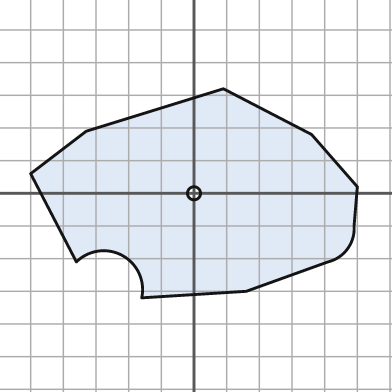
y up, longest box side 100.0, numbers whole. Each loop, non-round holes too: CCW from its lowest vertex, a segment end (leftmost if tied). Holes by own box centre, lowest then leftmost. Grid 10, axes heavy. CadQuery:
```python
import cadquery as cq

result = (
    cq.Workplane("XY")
    .moveTo(-16.0, -32.0)
    .lineTo(16.0, -30.0)
    .lineTo(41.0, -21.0)
    .threePointArc((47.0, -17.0), (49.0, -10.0))
    .lineTo(50.0, 2.0)
    .lineTo(36.0, 18.0)
    .lineTo(9.0, 32.0)
    .lineTo(-33.0, 19.0)
    .lineTo(-50.0, 6.0)
    .lineTo(-36.0, -21.0)
    .threePointArc((-22.0, -19.0), (-16.0, -32.0))
    .close()
    .moveTo(0.0, 0.0)
    .circle(2.0)
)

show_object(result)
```